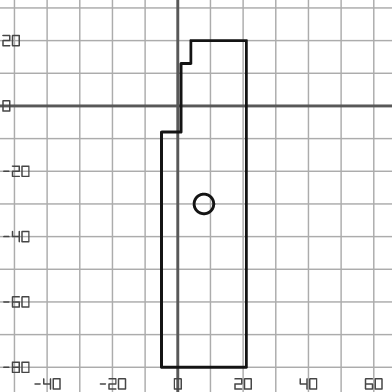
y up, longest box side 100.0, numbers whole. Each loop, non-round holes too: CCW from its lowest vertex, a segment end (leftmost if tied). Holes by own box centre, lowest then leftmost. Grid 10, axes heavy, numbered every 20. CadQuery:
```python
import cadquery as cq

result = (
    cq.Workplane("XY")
    .moveTo(-5.0, -80.0)
    .lineTo(21.0, -80.0)
    .lineTo(21.0, 20.0)
    .lineTo(4.0, 20.0)
    .lineTo(4.0, 13.0)
    .lineTo(1.0, 13.0)
    .lineTo(1.0, -8.0)
    .lineTo(-5.0, -8.0)
    .close()
    .moveTo(8.0, -30.0)
    .circle(3.0)
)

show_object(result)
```